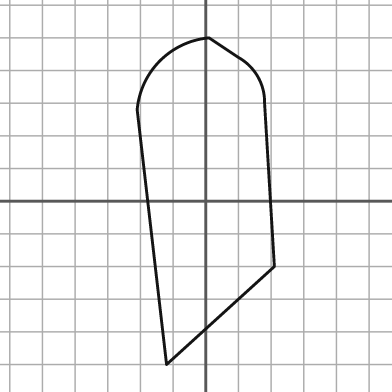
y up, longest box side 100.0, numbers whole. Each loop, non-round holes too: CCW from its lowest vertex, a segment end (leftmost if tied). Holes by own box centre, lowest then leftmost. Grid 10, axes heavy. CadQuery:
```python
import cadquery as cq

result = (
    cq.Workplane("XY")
    .moveTo(-12.0, -50.0)
    .lineTo(21.0, -20.0)
    .lineTo(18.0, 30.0)
    .threePointArc((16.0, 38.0), (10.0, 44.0))
    .lineTo(1.0, 50.0)
    .threePointArc((-14.0, 43.0), (-21.0, 28.0))
    .close()
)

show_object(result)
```